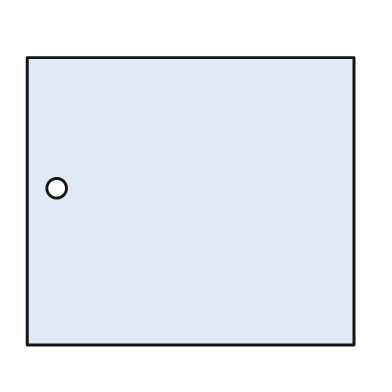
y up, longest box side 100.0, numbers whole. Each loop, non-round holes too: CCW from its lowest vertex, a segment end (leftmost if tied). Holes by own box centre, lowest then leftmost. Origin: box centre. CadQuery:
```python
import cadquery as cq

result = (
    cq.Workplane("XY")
    .moveTo(-50.0, -44.0)
    .lineTo(50.0, -44.0)
    .lineTo(50.0, 44.0)
    .lineTo(-50.0, 44.0)
    .close()
    .moveTo(-41.0, 4.0)
    .circle(3.0)
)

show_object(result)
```